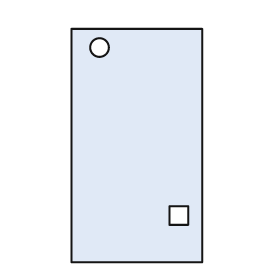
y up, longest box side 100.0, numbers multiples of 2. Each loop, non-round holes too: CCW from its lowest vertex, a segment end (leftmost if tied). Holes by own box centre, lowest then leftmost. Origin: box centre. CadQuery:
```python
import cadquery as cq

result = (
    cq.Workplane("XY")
    .moveTo(-28.0, -50.0)
    .lineTo(28.0, -50.0)
    .lineTo(28.0, 50.0)
    .lineTo(-28.0, 50.0)
    .close()
    .moveTo(14.0, -34.0)
    .lineTo(22.0, -34.0)
    .lineTo(22.0, -26.0)
    .lineTo(14.0, -26.0)
    .close()
    .moveTo(-16.0, 42.0)
    .circle(4.0)
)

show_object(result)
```